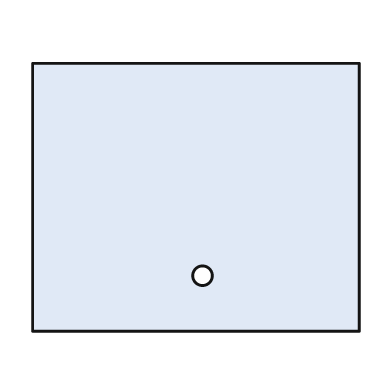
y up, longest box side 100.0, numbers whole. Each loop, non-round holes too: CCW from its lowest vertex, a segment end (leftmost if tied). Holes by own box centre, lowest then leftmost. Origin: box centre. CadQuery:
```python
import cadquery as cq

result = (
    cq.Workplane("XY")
    .moveTo(-50.0, -41.0)
    .lineTo(50.0, -41.0)
    .lineTo(50.0, 41.0)
    .lineTo(-50.0, 41.0)
    .close()
    .moveTo(2.0, -24.0)
    .circle(3.0)
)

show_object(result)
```